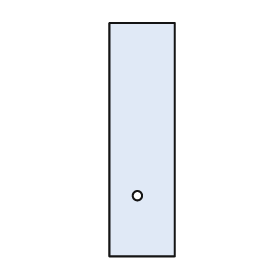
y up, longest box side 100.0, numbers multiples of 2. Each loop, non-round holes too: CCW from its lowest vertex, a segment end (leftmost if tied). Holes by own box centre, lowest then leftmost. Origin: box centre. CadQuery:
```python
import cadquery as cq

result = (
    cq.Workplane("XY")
    .moveTo(-14.0, -50.0)
    .lineTo(14.0, -50.0)
    .lineTo(14.0, 50.0)
    .lineTo(-14.0, 50.0)
    .close()
    .moveTo(-2.0, -24.0)
    .circle(2.0)
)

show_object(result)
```